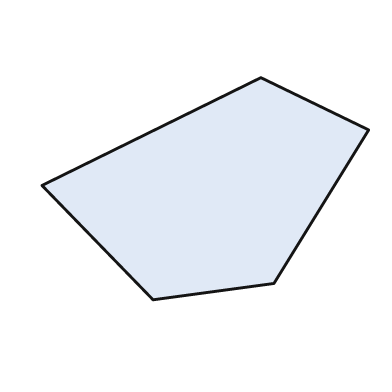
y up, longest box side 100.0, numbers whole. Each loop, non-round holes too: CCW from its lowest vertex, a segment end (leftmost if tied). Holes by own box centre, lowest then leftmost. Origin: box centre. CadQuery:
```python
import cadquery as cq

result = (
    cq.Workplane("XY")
    .moveTo(-16.0, -34.0)
    .lineTo(21.0, -29.0)
    .lineTo(50.0, 18.0)
    .lineTo(17.0, 34.0)
    .lineTo(-50.0, 1.0)
    .close()
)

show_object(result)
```